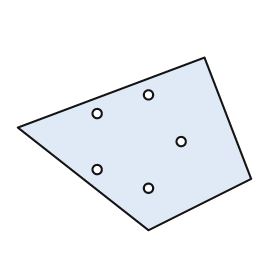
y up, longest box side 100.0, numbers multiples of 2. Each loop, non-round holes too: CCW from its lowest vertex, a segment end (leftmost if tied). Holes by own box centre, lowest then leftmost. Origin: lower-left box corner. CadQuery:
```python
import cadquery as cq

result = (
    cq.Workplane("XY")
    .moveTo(56.0, 0.0)
    .lineTo(100.0, 22.0)
    .lineTo(80.0, 74.0)
    .lineTo(0.0, 44.0)
    .close()
    .moveTo(56.0, 18.0)
    .circle(2.0)
    .moveTo(34.0, 26.0)
    .circle(2.0)
    .moveTo(70.0, 38.0)
    .circle(2.0)
    .moveTo(34.0, 50.0)
    .circle(2.0)
    .moveTo(56.0, 58.0)
    .circle(2.0)
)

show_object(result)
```